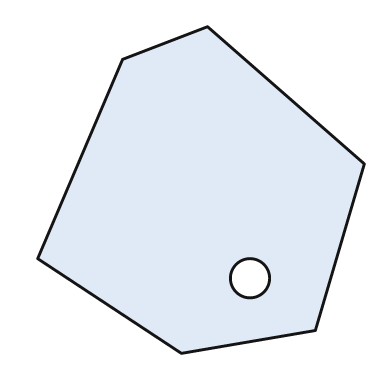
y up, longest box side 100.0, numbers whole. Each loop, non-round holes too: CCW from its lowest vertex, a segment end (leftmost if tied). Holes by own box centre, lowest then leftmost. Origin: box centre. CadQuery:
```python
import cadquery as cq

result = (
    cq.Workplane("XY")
    .moveTo(-6.0, -50.0)
    .lineTo(35.0, -43.0)
    .lineTo(50.0, 8.0)
    .lineTo(2.0, 50.0)
    .lineTo(-24.0, 40.0)
    .lineTo(-50.0, -21.0)
    .close()
    .moveTo(15.0, -27.0)
    .circle(6.0)
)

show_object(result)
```